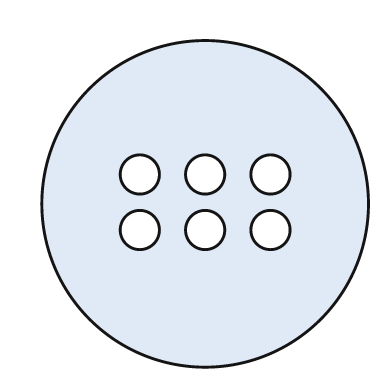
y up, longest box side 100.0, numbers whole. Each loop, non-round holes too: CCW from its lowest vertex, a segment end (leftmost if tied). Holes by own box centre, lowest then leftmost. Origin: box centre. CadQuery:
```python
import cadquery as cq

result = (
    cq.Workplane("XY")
    .moveTo(0.0, 0.0)
    .circle(50.0)
    .moveTo(-20.0, -8.0)
    .circle(6.0)
    .moveTo(0.0, -8.0)
    .circle(6.0)
    .moveTo(20.0, -8.0)
    .circle(6.0)
    .moveTo(-20.0, 9.0)
    .circle(6.0)
    .moveTo(0.0, 9.0)
    .circle(6.0)
    .moveTo(20.0, 9.0)
    .circle(6.0)
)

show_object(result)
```